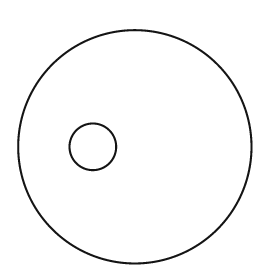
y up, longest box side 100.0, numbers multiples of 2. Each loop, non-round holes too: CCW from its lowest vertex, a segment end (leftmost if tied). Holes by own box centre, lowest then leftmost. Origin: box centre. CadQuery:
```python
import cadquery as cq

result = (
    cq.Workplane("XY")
    .moveTo(0.0, 0.0)
    .circle(50.0)
    .moveTo(-18.0, 0.0)
    .circle(10.0)
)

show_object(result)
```